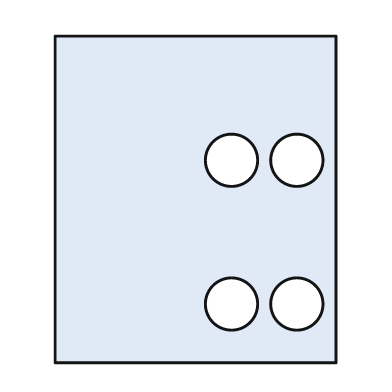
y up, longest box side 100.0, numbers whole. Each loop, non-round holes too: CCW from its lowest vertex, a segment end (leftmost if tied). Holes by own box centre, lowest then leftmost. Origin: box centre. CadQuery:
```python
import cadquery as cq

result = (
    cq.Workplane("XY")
    .moveTo(-43.0, -50.0)
    .lineTo(43.0, -50.0)
    .lineTo(43.0, 50.0)
    .lineTo(-43.0, 50.0)
    .close()
    .moveTo(11.0, -32.0)
    .circle(8.0)
    .moveTo(31.0, -32.0)
    .circle(8.0)
    .moveTo(11.0, 12.0)
    .circle(8.0)
    .moveTo(31.0, 12.0)
    .circle(8.0)
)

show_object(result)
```